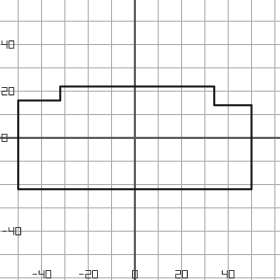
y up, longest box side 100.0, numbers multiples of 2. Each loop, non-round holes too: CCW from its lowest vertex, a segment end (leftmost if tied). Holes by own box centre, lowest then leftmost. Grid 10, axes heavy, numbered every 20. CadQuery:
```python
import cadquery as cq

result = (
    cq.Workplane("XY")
    .moveTo(-50.0, -22.0)
    .lineTo(50.0, -22.0)
    .lineTo(50.0, 14.0)
    .lineTo(34.0, 14.0)
    .lineTo(34.0, 22.0)
    .lineTo(-32.0, 22.0)
    .lineTo(-32.0, 16.0)
    .lineTo(-50.0, 16.0)
    .close()
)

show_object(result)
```